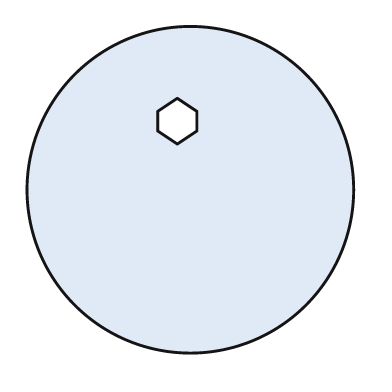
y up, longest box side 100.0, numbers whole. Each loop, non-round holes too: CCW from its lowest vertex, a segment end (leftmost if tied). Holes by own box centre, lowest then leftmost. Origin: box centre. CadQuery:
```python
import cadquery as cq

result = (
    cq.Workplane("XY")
    .moveTo(0.0, 0.0)
    .circle(50.0)
    .moveTo(-4.0, 14.0)
    .lineTo(2.0, 18.0)
    .lineTo(2.0, 24.0)
    .lineTo(-4.0, 28.0)
    .lineTo(-10.0, 24.0)
    .lineTo(-10.0, 18.0)
    .close()
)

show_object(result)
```